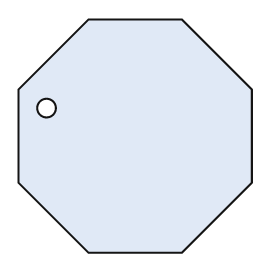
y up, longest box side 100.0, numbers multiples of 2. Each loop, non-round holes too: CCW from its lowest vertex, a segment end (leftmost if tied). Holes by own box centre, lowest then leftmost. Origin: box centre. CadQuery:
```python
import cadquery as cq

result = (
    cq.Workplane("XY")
    .moveTo(-20.0, -50.0)
    .lineTo(20.0, -50.0)
    .lineTo(50.0, -20.0)
    .lineTo(50.0, 20.0)
    .lineTo(20.0, 50.0)
    .lineTo(-20.0, 50.0)
    .lineTo(-50.0, 20.0)
    .lineTo(-50.0, -20.0)
    .close()
    .moveTo(-38.0, 12.0)
    .circle(4.0)
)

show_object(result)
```